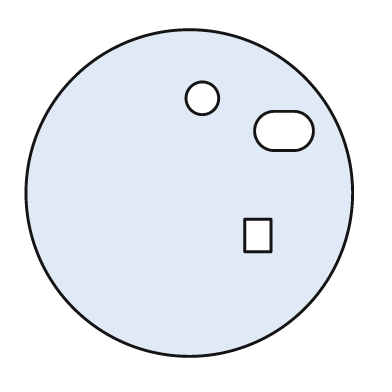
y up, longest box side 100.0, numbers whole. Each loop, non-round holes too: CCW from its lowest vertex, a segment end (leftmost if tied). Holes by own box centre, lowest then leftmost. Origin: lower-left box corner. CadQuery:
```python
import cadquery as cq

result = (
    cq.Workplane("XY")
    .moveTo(50.0, 50.0)
    .circle(50.0)
    .moveTo(67.0, 32.0)
    .lineTo(75.0, 32.0)
    .lineTo(75.0, 42.0)
    .lineTo(67.0, 42.0)
    .close()
    .moveTo(76.0, 63.0)
    .lineTo(82.0, 63.0)
    .threePointArc((88.0, 69.0), (82.0, 75.0))
    .lineTo(76.0, 75.0)
    .threePointArc((70.0, 69.0), (76.0, 63.0))
    .close()
    .moveTo(54.0, 79.0)
    .circle(5.0)
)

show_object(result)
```